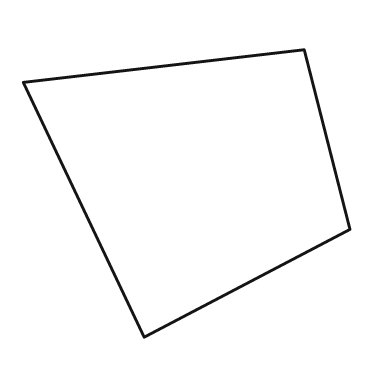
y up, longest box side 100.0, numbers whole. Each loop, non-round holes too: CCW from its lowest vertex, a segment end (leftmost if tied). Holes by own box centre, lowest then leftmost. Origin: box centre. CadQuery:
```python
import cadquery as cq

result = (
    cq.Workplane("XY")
    .moveTo(-13.0, -44.0)
    .lineTo(50.0, -11.0)
    .lineTo(36.0, 44.0)
    .lineTo(-50.0, 34.0)
    .close()
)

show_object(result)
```